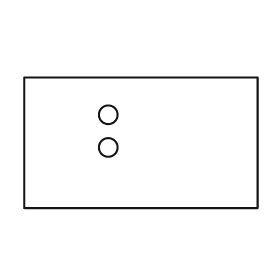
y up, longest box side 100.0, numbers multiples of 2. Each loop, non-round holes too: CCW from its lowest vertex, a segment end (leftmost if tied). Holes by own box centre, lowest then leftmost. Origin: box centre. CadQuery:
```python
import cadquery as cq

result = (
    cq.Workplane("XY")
    .moveTo(-50.0, -28.0)
    .lineTo(50.0, -28.0)
    .lineTo(50.0, 28.0)
    .lineTo(-50.0, 28.0)
    .close()
    .moveTo(-14.0, -2.0)
    .circle(4.0)
    .moveTo(-14.0, 12.0)
    .circle(4.0)
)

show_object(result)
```